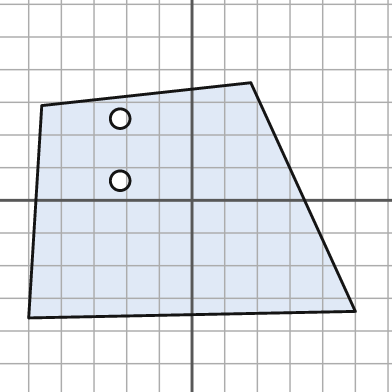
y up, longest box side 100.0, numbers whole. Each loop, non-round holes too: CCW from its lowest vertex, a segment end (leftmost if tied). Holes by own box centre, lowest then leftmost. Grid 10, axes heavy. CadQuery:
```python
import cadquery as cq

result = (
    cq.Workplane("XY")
    .moveTo(-50.0, -36.0)
    .lineTo(50.0, -34.0)
    .lineTo(18.0, 36.0)
    .lineTo(-46.0, 29.0)
    .close()
    .moveTo(-22.0, 6.0)
    .circle(3.0)
    .moveTo(-22.0, 25.0)
    .circle(3.0)
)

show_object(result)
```